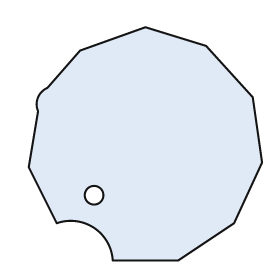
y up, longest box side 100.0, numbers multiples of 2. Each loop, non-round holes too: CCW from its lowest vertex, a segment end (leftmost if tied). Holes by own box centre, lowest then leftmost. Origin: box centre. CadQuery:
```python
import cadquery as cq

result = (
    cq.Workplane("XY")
    .moveTo(-14.0, -50.0)
    .lineTo(14.0, -50.0)
    .lineTo(38.0, -34.0)
    .lineTo(50.0, -8.0)
    .lineTo(46.0, 20.0)
    .lineTo(26.0, 42.0)
    .lineTo(0.0, 50.0)
    .lineTo(-28.0, 40.0)
    .lineTo(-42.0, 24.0)
    .threePointArc((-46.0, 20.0), (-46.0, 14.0))
    .lineTo(-50.0, -10.0)
    .lineTo(-38.0, -34.0)
    .threePointArc((-22.0, -36.0), (-14.0, -50.0))
    .close()
    .moveTo(-22.0, -22.0)
    .circle(4.0)
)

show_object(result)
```